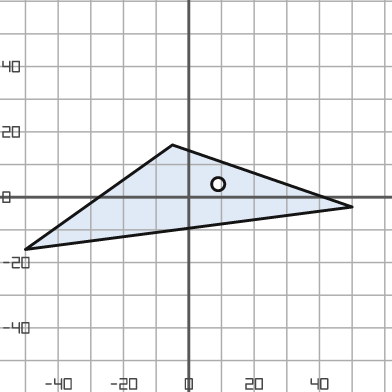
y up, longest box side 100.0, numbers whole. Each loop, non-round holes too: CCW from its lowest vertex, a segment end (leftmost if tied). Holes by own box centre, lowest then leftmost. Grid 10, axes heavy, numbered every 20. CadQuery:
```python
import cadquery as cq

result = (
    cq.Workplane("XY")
    .moveTo(-50.0, -16.0)
    .lineTo(50.0, -3.0)
    .lineTo(-5.0, 16.0)
    .close()
    .moveTo(9.0, 4.0)
    .circle(2.0)
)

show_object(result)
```